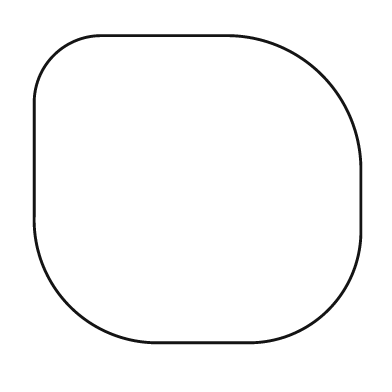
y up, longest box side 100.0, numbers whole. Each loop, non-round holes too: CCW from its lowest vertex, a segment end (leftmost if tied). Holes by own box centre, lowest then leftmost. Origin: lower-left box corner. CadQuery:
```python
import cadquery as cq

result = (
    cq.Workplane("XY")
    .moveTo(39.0, 0.0)
    .lineTo(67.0, 0.0)
    .threePointArc((90.0, 10.0), (100.0, 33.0))
    .lineTo(100.0, 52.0)
    .threePointArc((88.0, 82.0), (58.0, 94.0))
    .lineTo(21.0, 94.0)
    .threePointArc((6.0, 88.0), (0.0, 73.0))
    .lineTo(0.0, 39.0)
    .threePointArc((11.0, 11.0), (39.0, 0.0))
    .close()
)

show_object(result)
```